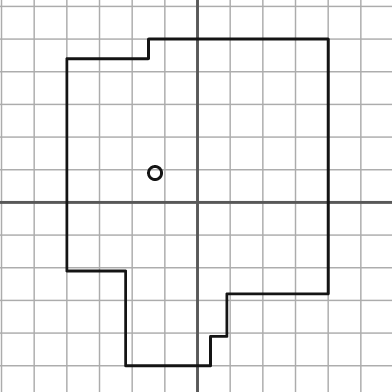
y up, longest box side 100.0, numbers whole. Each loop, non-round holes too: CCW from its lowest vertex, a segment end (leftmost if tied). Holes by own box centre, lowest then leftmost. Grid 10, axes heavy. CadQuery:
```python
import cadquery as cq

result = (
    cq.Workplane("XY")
    .moveTo(-22.0, -50.0)
    .lineTo(4.0, -50.0)
    .lineTo(4.0, -41.0)
    .lineTo(9.0, -41.0)
    .lineTo(9.0, -28.0)
    .lineTo(40.0, -28.0)
    .lineTo(40.0, 50.0)
    .lineTo(-15.0, 50.0)
    .lineTo(-15.0, 44.0)
    .lineTo(-40.0, 44.0)
    .lineTo(-40.0, -21.0)
    .lineTo(-22.0, -21.0)
    .close()
    .moveTo(-13.0, 9.0)
    .circle(2.0)
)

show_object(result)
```